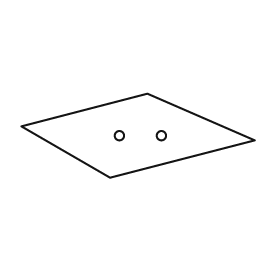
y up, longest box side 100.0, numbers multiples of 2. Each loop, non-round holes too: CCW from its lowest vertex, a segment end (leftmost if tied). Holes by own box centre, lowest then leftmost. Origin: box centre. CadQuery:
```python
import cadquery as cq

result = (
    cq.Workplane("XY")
    .moveTo(-12.0, -18.0)
    .lineTo(50.0, -2.0)
    .lineTo(4.0, 18.0)
    .lineTo(-50.0, 4.0)
    .close()
    .moveTo(-8.0, 0.0)
    .circle(2.0)
    .moveTo(10.0, 0.0)
    .circle(2.0)
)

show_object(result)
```